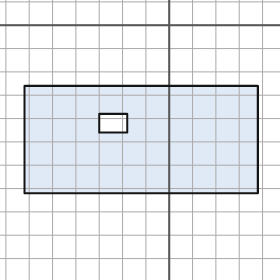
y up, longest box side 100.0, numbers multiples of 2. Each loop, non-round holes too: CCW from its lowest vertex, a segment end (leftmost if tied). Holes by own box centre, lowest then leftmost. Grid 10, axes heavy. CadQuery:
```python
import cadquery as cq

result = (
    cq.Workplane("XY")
    .moveTo(-62.0, -72.0)
    .lineTo(38.0, -72.0)
    .lineTo(38.0, -26.0)
    .lineTo(-62.0, -26.0)
    .close()
    .moveTo(-30.0, -46.0)
    .lineTo(-18.0, -46.0)
    .lineTo(-18.0, -38.0)
    .lineTo(-30.0, -38.0)
    .close()
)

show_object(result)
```